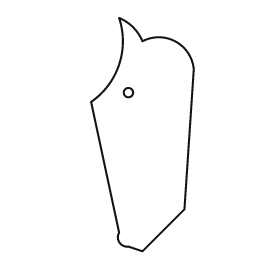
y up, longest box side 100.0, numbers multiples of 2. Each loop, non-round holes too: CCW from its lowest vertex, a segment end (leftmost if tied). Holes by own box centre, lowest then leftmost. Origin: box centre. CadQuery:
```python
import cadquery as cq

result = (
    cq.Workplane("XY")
    .moveTo(0.0, -50.0)
    .lineTo(18.0, -32.0)
    .lineTo(22.0, 28.0)
    .threePointArc((14.0, 40.0), (0.0, 40.0))
    .threePointArc((-4.0, 46.0), (-10.0, 50.0))
    .threePointArc((-10.0, 30.0), (-22.0, 14.0))
    .lineTo(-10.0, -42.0)
    .threePointArc((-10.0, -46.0), (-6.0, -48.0))
    .close()
    .moveTo(-6.0, 18.0)
    .circle(2.0)
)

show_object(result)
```